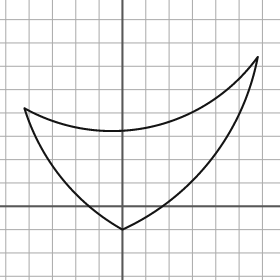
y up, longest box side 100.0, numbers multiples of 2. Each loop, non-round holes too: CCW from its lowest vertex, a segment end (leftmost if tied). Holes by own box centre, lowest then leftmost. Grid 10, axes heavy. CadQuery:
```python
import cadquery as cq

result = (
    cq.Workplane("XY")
    .moveTo(0.0, -10.0)
    .threePointArc((38.0, 20.0), (58.0, 64.0))
    .threePointArc((12.0, 34.0), (-42.0, 42.0))
    .threePointArc((-26.0, 12.0), (0.0, -10.0))
    .close()
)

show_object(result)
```